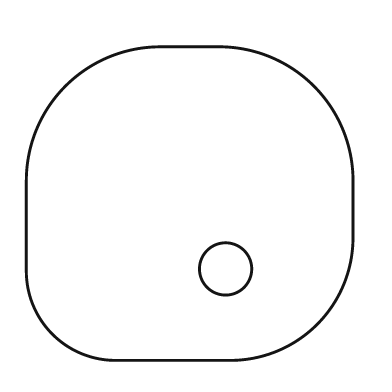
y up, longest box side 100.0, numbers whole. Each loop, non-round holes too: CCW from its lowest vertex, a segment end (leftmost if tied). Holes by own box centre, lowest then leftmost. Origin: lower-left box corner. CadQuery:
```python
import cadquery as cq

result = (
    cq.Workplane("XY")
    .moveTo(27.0, 0.0)
    .lineTo(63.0, 0.0)
    .threePointArc((89.0, 11.0), (100.0, 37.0))
    .lineTo(100.0, 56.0)
    .threePointArc((88.0, 84.0), (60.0, 96.0))
    .lineTo(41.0, 96.0)
    .threePointArc((12.0, 84.0), (0.0, 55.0))
    .lineTo(0.0, 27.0)
    .threePointArc((8.0, 8.0), (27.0, 0.0))
    .close()
    .moveTo(61.0, 28.0)
    .circle(8.0)
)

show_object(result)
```